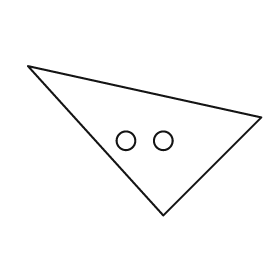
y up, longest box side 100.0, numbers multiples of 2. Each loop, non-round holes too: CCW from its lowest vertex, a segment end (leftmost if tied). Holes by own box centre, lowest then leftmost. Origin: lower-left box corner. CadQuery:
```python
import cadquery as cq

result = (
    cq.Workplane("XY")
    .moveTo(58.0, 0.0)
    .lineTo(100.0, 42.0)
    .lineTo(0.0, 64.0)
    .close()
    .moveTo(42.0, 32.0)
    .circle(4.0)
    .moveTo(58.0, 32.0)
    .circle(4.0)
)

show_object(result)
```